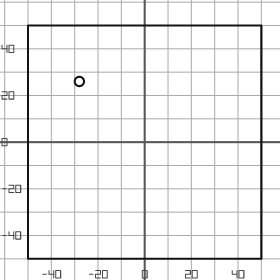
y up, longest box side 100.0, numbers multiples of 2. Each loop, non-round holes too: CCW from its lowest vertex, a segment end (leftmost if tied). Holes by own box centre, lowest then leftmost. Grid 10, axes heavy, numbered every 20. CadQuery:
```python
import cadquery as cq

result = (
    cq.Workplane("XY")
    .moveTo(-50.0, -50.0)
    .lineTo(50.0, -50.0)
    .lineTo(50.0, 50.0)
    .lineTo(-50.0, 50.0)
    .close()
    .moveTo(-28.0, 26.0)
    .circle(2.0)
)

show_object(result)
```